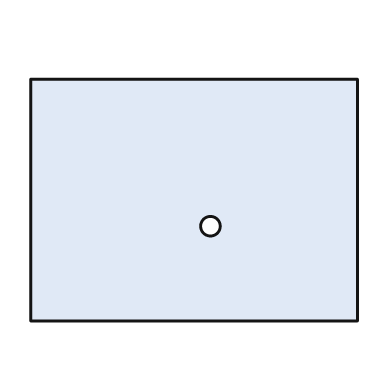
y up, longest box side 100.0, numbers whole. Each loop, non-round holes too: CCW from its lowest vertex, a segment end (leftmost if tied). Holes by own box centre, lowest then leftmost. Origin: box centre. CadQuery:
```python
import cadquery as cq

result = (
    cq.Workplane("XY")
    .moveTo(-50.0, -37.0)
    .lineTo(50.0, -37.0)
    .lineTo(50.0, 37.0)
    .lineTo(-50.0, 37.0)
    .close()
    .moveTo(5.0, -8.0)
    .circle(3.0)
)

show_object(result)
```